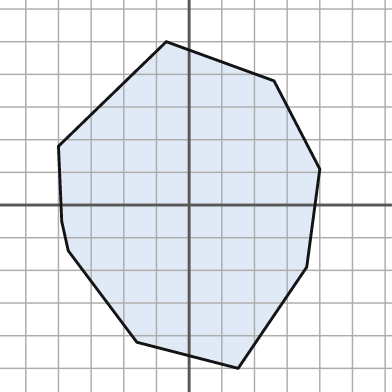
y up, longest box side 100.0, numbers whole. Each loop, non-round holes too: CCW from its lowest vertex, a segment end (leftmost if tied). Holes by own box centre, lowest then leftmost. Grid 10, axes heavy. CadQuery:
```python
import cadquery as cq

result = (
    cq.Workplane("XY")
    .moveTo(15.0, -50.0)
    .lineTo(36.0, -19.0)
    .lineTo(40.0, 11.0)
    .lineTo(26.0, 38.0)
    .lineTo(-7.0, 50.0)
    .lineTo(-40.0, 18.0)
    .lineTo(-39.0, -5.0)
    .lineTo(-37.0, -14.0)
    .lineTo(-16.0, -42.0)
    .close()
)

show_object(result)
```